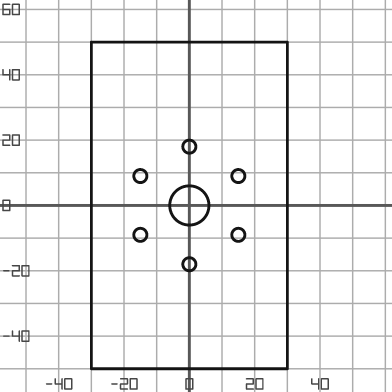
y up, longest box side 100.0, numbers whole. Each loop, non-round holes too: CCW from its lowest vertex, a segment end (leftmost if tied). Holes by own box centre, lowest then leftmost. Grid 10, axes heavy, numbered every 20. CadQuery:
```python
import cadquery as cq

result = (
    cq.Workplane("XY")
    .moveTo(-30.0, -50.0)
    .lineTo(30.0, -50.0)
    .lineTo(30.0, 50.0)
    .lineTo(-30.0, 50.0)
    .close()
    .moveTo(0.0, -18.0)
    .circle(2.0)
    .moveTo(-15.0, -9.0)
    .circle(2.0)
    .moveTo(15.0, -9.0)
    .circle(2.0)
    .moveTo(0.0, 0.0)
    .circle(6.0)
    .moveTo(-15.0, 9.0)
    .circle(2.0)
    .moveTo(15.0, 9.0)
    .circle(2.0)
    .moveTo(0.0, 18.0)
    .circle(2.0)
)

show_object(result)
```